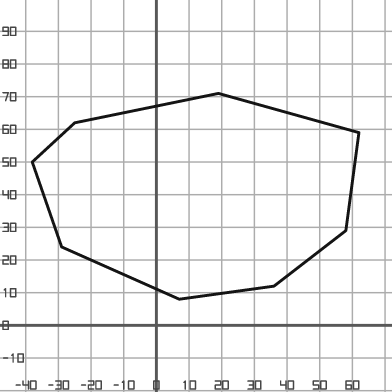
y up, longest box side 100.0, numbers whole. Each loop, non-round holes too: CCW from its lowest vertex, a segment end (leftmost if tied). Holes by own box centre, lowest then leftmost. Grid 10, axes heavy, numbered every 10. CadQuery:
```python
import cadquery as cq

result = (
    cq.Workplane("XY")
    .moveTo(7.0, 8.0)
    .lineTo(36.0, 12.0)
    .lineTo(58.0, 29.0)
    .lineTo(62.0, 59.0)
    .lineTo(19.0, 71.0)
    .lineTo(-25.0, 62.0)
    .lineTo(-38.0, 50.0)
    .lineTo(-29.0, 24.0)
    .close()
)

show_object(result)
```